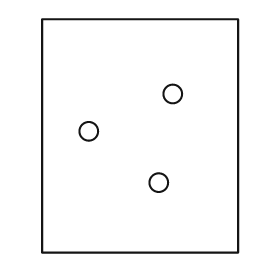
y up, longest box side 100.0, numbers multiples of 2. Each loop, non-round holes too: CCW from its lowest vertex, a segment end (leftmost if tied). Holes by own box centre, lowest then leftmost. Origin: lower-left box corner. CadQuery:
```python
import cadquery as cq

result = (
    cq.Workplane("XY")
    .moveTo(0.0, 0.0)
    .lineTo(84.0, 0.0)
    .lineTo(84.0, 100.0)
    .lineTo(0.0, 100.0)
    .close()
    .moveTo(50.0, 30.0)
    .circle(4.0)
    .moveTo(20.0, 52.0)
    .circle(4.0)
    .moveTo(56.0, 68.0)
    .circle(4.0)
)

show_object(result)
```